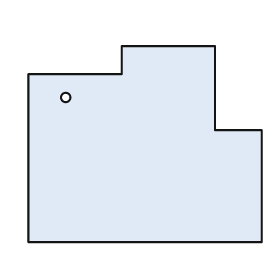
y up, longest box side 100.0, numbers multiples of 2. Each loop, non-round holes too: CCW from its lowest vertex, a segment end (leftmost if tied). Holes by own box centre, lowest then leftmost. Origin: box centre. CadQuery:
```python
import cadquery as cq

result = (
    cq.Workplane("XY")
    .moveTo(-50.0, -42.0)
    .lineTo(50.0, -42.0)
    .lineTo(50.0, 6.0)
    .lineTo(30.0, 6.0)
    .lineTo(30.0, 42.0)
    .lineTo(-10.0, 42.0)
    .lineTo(-10.0, 30.0)
    .lineTo(-50.0, 30.0)
    .close()
    .moveTo(-34.0, 20.0)
    .circle(2.0)
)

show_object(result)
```